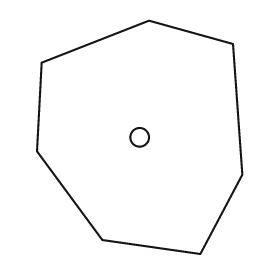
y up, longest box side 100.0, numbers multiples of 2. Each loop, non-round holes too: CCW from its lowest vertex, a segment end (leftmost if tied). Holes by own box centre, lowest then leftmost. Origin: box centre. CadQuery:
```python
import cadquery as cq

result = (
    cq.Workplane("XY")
    .moveTo(26.0, -50.0)
    .lineTo(44.0, -16.0)
    .lineTo(40.0, 40.0)
    .lineTo(4.0, 50.0)
    .lineTo(-42.0, 32.0)
    .lineTo(-44.0, -6.0)
    .lineTo(-16.0, -44.0)
    .close()
    .moveTo(0.0, 0.0)
    .circle(4.0)
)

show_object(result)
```